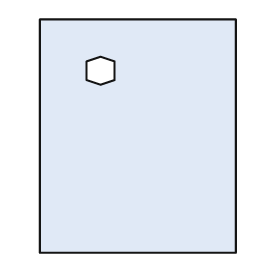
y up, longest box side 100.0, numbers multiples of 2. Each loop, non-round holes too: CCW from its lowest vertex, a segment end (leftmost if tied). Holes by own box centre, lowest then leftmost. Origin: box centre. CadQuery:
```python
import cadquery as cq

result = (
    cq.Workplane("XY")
    .moveTo(-42.0, -50.0)
    .lineTo(42.0, -50.0)
    .lineTo(42.0, 50.0)
    .lineTo(-42.0, 50.0)
    .close()
    .moveTo(-16.0, 22.0)
    .lineTo(-10.0, 24.0)
    .lineTo(-10.0, 32.0)
    .lineTo(-16.0, 34.0)
    .lineTo(-22.0, 32.0)
    .lineTo(-22.0, 24.0)
    .close()
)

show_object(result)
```